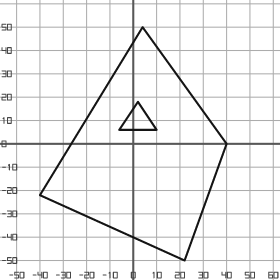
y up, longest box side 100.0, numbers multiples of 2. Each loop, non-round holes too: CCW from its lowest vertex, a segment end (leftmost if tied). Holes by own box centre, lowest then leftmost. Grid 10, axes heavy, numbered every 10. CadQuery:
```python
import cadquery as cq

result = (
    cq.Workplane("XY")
    .moveTo(22.0, -50.0)
    .lineTo(40.0, 0.0)
    .lineTo(4.0, 50.0)
    .lineTo(-40.0, -22.0)
    .close()
    .moveTo(-6.0, 6.0)
    .lineTo(10.0, 6.0)
    .lineTo(2.0, 18.0)
    .close()
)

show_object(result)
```